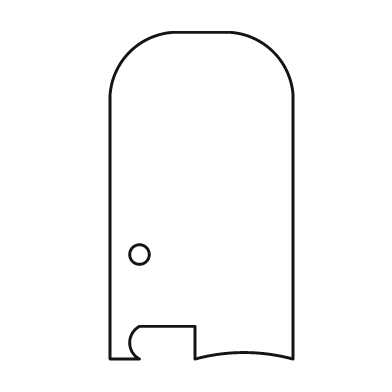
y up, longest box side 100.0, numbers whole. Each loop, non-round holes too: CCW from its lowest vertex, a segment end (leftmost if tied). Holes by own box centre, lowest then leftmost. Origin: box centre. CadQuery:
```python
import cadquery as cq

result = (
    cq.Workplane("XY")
    .moveTo(-28.0, -50.0)
    .lineTo(-19.0, -50.0)
    .threePointArc((-22.0, -45.0), (-19.0, -40.0))
    .lineTo(-2.0, -40.0)
    .lineTo(-2.0, -50.0)
    .threePointArc((13.0, -48.0), (28.0, -50.0))
    .lineTo(28.0, 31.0)
    .threePointArc((22.0, 44.0), (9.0, 50.0))
    .lineTo(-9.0, 50.0)
    .threePointArc((-22.0, 44.0), (-28.0, 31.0))
    .close()
    .moveTo(-19.0, -18.0)
    .circle(3.0)
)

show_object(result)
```